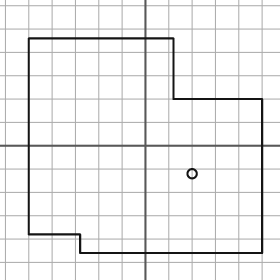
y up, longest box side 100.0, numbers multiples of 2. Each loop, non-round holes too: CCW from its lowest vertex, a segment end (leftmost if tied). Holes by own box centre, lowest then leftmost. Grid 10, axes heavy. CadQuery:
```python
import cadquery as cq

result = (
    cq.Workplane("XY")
    .moveTo(-28.0, -46.0)
    .lineTo(50.0, -46.0)
    .lineTo(50.0, 20.0)
    .lineTo(12.0, 20.0)
    .lineTo(12.0, 46.0)
    .lineTo(-50.0, 46.0)
    .lineTo(-50.0, -38.0)
    .lineTo(-28.0, -38.0)
    .close()
    .moveTo(20.0, -12.0)
    .circle(2.0)
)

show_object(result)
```